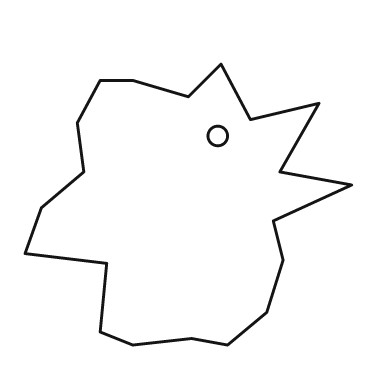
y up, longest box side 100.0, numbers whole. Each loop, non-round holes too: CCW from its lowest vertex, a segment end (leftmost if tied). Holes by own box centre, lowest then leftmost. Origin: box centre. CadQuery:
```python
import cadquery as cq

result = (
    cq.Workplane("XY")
    .moveTo(-17.0, -43.0)
    .lineTo(1.0, -41.0)
    .lineTo(12.0, -43.0)
    .lineTo(24.0, -33.0)
    .lineTo(29.0, -17.0)
    .lineTo(26.0, -5.0)
    .lineTo(50.0, 6.0)
    .lineTo(28.0, 10.0)
    .lineTo(40.0, 31.0)
    .lineTo(19.0, 26.0)
    .lineTo(10.0, 43.0)
    .lineTo(0.0, 33.0)
    .lineTo(-17.0, 38.0)
    .lineTo(-27.0, 38.0)
    .lineTo(-34.0, 25.0)
    .lineTo(-32.0, 10.0)
    .lineTo(-45.0, -1.0)
    .lineTo(-50.0, -15.0)
    .lineTo(-25.0, -18.0)
    .lineTo(-27.0, -39.0)
    .close()
    .moveTo(9.0, 21.0)
    .circle(3.0)
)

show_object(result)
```